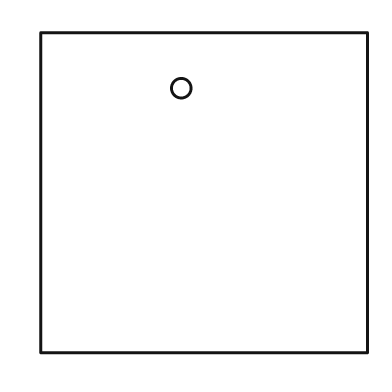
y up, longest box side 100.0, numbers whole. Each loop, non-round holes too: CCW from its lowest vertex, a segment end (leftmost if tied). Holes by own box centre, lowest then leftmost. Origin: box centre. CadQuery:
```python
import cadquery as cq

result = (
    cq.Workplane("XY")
    .moveTo(-50.0, -49.0)
    .lineTo(50.0, -49.0)
    .lineTo(50.0, 49.0)
    .lineTo(-50.0, 49.0)
    .close()
    .moveTo(-7.0, 32.0)
    .circle(3.0)
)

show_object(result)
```